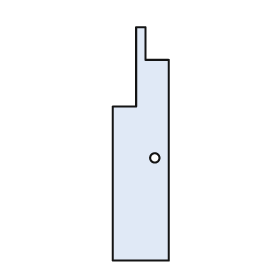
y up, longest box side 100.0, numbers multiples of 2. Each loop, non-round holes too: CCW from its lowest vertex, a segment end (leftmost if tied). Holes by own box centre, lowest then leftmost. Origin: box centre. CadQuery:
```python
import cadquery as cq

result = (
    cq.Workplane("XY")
    .moveTo(-12.0, -50.0)
    .lineTo(12.0, -50.0)
    .lineTo(12.0, 36.0)
    .lineTo(2.0, 36.0)
    .lineTo(2.0, 50.0)
    .lineTo(-2.0, 50.0)
    .lineTo(-2.0, 16.0)
    .lineTo(-12.0, 16.0)
    .close()
    .moveTo(6.0, -6.0)
    .circle(2.0)
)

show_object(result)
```